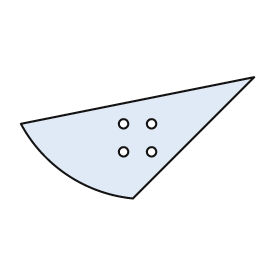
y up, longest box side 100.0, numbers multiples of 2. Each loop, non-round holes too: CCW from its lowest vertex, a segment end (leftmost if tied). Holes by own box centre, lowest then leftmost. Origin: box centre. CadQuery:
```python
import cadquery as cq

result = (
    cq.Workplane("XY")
    .moveTo(-2.0, -26.0)
    .lineTo(50.0, 26.0)
    .lineTo(-50.0, 6.0)
    .threePointArc((-30.0, -16.0), (-2.0, -26.0))
    .close()
    .moveTo(-6.0, -6.0)
    .circle(2.0)
    .moveTo(6.0, -6.0)
    .circle(2.0)
    .moveTo(-6.0, 6.0)
    .circle(2.0)
    .moveTo(6.0, 6.0)
    .circle(2.0)
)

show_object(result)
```